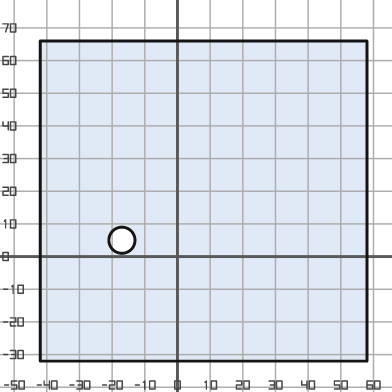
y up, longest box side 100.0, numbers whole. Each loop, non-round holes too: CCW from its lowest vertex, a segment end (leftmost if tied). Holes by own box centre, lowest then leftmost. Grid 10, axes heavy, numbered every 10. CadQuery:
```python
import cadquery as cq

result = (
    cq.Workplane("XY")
    .moveTo(-42.0, -32.0)
    .lineTo(58.0, -32.0)
    .lineTo(58.0, 66.0)
    .lineTo(-42.0, 66.0)
    .close()
    .moveTo(-17.0, 5.0)
    .circle(4.0)
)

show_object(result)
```